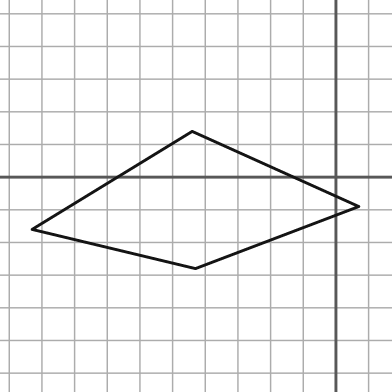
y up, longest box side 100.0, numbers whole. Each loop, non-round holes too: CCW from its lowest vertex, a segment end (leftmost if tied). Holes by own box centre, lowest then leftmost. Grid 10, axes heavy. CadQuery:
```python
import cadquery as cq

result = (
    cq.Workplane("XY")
    .moveTo(-43.0, -28.0)
    .lineTo(7.0, -9.0)
    .lineTo(-44.0, 14.0)
    .lineTo(-93.0, -16.0)
    .close()
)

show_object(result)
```